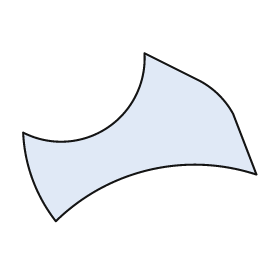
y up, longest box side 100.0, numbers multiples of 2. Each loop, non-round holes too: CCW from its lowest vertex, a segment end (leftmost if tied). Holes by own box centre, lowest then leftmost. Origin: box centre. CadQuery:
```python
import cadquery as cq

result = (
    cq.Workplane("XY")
    .moveTo(-36.0, -36.0)
    .threePointArc((4.0, -14.0), (50.0, -16.0))
    .lineTo(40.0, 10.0)
    .threePointArc((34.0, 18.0), (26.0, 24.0))
    .lineTo(2.0, 36.0)
    .threePointArc((-14.0, 4.0), (-50.0, 2.0))
    .threePointArc((-46.0, -18.0), (-36.0, -36.0))
    .close()
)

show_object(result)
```